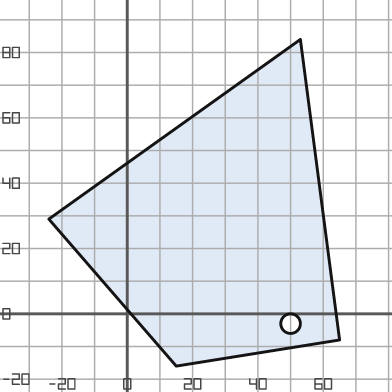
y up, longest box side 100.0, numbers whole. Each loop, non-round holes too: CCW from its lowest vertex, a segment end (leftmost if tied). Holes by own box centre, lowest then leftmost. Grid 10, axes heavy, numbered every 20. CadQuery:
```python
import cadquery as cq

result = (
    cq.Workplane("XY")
    .moveTo(15.0, -16.0)
    .lineTo(65.0, -8.0)
    .lineTo(53.0, 84.0)
    .lineTo(-24.0, 29.0)
    .close()
    .moveTo(50.0, -3.0)
    .circle(3.0)
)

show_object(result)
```